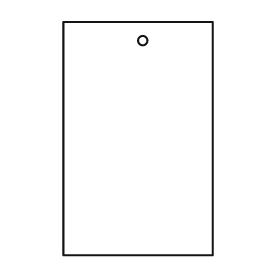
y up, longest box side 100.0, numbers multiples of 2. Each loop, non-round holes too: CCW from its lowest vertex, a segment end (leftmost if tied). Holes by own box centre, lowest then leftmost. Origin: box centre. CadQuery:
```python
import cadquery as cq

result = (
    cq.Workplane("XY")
    .moveTo(-32.0, -50.0)
    .lineTo(32.0, -50.0)
    .lineTo(32.0, 50.0)
    .lineTo(-32.0, 50.0)
    .close()
    .moveTo(2.0, 42.0)
    .circle(2.0)
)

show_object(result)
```